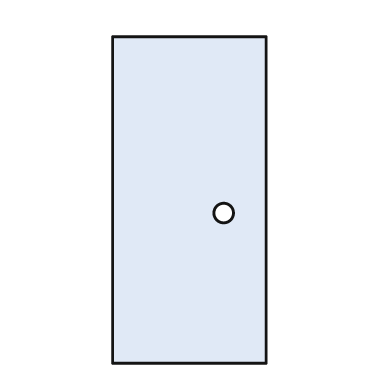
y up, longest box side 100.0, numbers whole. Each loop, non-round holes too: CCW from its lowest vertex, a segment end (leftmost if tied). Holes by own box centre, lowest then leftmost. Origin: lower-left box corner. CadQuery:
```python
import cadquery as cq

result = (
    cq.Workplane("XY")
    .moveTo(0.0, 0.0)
    .lineTo(47.0, 0.0)
    .lineTo(47.0, 100.0)
    .lineTo(0.0, 100.0)
    .close()
    .moveTo(34.0, 46.0)
    .circle(3.0)
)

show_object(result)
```